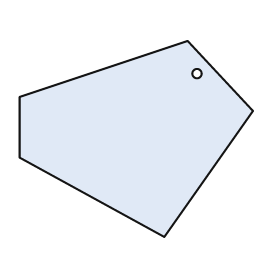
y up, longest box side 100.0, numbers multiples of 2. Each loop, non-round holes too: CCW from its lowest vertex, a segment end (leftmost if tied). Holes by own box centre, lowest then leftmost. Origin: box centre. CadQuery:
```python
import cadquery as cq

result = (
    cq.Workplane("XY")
    .moveTo(12.0, -42.0)
    .lineTo(50.0, 12.0)
    .lineTo(22.0, 42.0)
    .lineTo(-50.0, 18.0)
    .lineTo(-50.0, -8.0)
    .close()
    .moveTo(26.0, 28.0)
    .circle(2.0)
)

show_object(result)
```